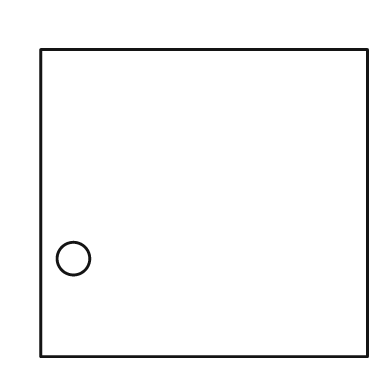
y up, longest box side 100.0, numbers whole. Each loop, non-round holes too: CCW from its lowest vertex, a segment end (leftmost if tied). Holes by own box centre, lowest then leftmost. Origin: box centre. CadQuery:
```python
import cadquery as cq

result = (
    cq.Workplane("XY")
    .moveTo(-50.0, -47.0)
    .lineTo(50.0, -47.0)
    .lineTo(50.0, 47.0)
    .lineTo(-50.0, 47.0)
    .close()
    .moveTo(-40.0, -17.0)
    .circle(5.0)
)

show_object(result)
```